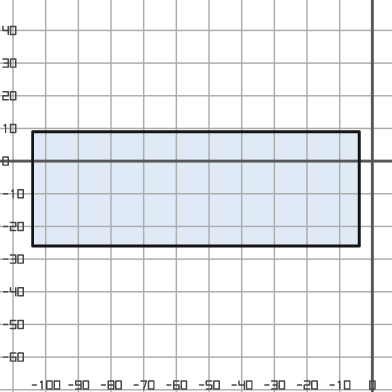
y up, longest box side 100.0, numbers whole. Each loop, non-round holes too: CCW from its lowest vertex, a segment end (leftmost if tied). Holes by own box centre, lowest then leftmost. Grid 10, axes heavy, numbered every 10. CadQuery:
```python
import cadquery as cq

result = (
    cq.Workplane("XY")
    .moveTo(-104.0, -26.0)
    .lineTo(-4.0, -26.0)
    .lineTo(-4.0, 9.0)
    .lineTo(-104.0, 9.0)
    .close()
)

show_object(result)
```